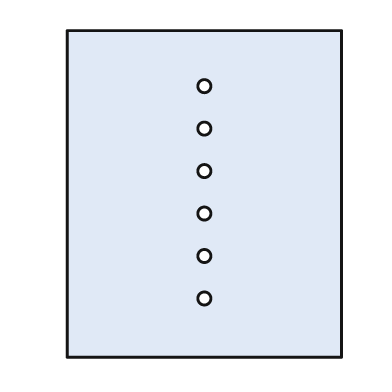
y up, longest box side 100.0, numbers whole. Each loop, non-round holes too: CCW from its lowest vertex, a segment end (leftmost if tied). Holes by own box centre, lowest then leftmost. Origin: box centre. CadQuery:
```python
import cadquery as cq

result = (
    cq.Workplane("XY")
    .moveTo(-42.0, -50.0)
    .lineTo(42.0, -50.0)
    .lineTo(42.0, 50.0)
    .lineTo(-42.0, 50.0)
    .close()
    .moveTo(0.0, -32.0)
    .circle(2.0)
    .moveTo(0.0, -19.0)
    .circle(2.0)
    .moveTo(0.0, -6.0)
    .circle(2.0)
    .moveTo(0.0, 7.0)
    .circle(2.0)
    .moveTo(0.0, 20.0)
    .circle(2.0)
    .moveTo(0.0, 33.0)
    .circle(2.0)
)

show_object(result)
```